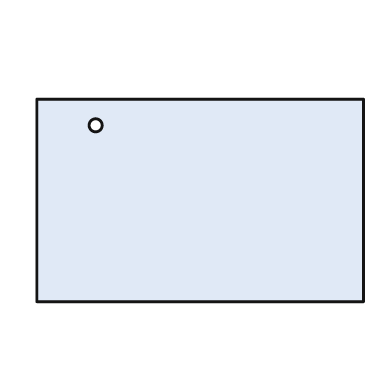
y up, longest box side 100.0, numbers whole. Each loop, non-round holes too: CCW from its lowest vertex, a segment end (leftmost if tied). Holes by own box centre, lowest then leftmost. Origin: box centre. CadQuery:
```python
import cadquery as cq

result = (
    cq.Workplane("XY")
    .moveTo(-50.0, -31.0)
    .lineTo(50.0, -31.0)
    .lineTo(50.0, 31.0)
    .lineTo(-50.0, 31.0)
    .close()
    .moveTo(-32.0, 23.0)
    .circle(2.0)
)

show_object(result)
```